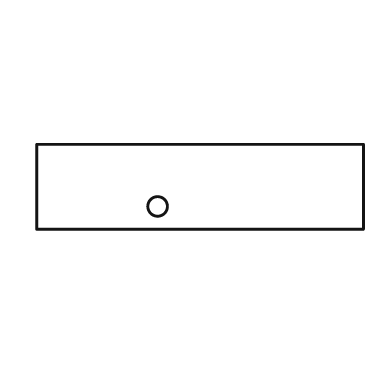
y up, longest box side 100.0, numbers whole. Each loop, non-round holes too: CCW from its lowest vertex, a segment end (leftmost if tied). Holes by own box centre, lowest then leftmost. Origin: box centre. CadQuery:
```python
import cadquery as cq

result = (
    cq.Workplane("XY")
    .moveTo(-50.0, -13.0)
    .lineTo(50.0, -13.0)
    .lineTo(50.0, 13.0)
    .lineTo(-50.0, 13.0)
    .close()
    .moveTo(-13.0, -6.0)
    .circle(3.0)
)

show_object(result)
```